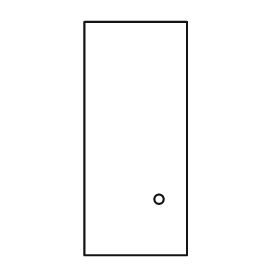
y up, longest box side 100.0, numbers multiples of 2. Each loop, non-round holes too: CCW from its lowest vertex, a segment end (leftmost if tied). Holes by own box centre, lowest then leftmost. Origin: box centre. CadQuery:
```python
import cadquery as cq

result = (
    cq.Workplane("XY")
    .moveTo(-22.0, -50.0)
    .lineTo(22.0, -50.0)
    .lineTo(22.0, 50.0)
    .lineTo(-22.0, 50.0)
    .close()
    .moveTo(10.0, -26.0)
    .circle(2.0)
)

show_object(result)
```